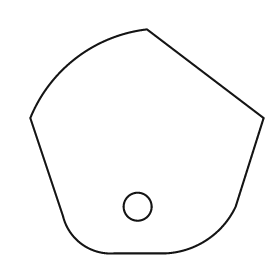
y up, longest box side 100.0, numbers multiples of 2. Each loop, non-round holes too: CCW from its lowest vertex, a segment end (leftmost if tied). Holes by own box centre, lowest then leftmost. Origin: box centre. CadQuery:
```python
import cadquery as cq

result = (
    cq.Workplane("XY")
    .moveTo(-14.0, -48.0)
    .lineTo(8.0, -48.0)
    .threePointArc((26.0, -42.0), (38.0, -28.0))
    .lineTo(50.0, 10.0)
    .lineTo(0.0, 48.0)
    .threePointArc((-30.0, 36.0), (-50.0, 10.0))
    .lineTo(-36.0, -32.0)
    .threePointArc((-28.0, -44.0), (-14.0, -48.0))
    .close()
    .moveTo(-4.0, -28.0)
    .circle(6.0)
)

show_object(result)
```